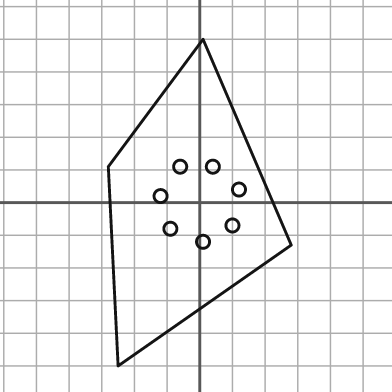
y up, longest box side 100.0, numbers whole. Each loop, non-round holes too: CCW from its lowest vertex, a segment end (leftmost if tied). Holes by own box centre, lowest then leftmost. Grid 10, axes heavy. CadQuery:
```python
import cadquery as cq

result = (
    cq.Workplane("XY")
    .moveTo(-25.0, -50.0)
    .lineTo(28.0, -13.0)
    .lineTo(1.0, 50.0)
    .lineTo(-28.0, 11.0)
    .close()
    .moveTo(1.0, -12.0)
    .circle(2.0)
    .moveTo(-9.0, -8.0)
    .circle(2.0)
    .moveTo(10.0, -7.0)
    .circle(2.0)
    .moveTo(-12.0, 2.0)
    .circle(2.0)
    .moveTo(12.0, 4.0)
    .circle(2.0)
    .moveTo(-6.0, 11.0)
    .circle(2.0)
    .moveTo(4.0, 11.0)
    .circle(2.0)
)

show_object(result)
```